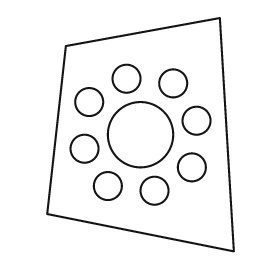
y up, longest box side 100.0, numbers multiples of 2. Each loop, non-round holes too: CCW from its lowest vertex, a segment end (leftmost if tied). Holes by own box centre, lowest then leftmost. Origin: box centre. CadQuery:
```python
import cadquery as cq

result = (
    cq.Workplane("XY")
    .moveTo(40.0, -50.0)
    .lineTo(34.0, 50.0)
    .lineTo(-32.0, 38.0)
    .lineTo(-40.0, -34.0)
    .close()
    .moveTo(6.0, -24.0)
    .circle(6.0)
    .moveTo(-14.0, -22.0)
    .circle(6.0)
    .moveTo(22.0, -14.0)
    .circle(6.0)
    .moveTo(-24.0, -6.0)
    .circle(6.0)
    .moveTo(0.0, 0.0)
    .circle(14.0)
    .moveTo(24.0, 6.0)
    .circle(6.0)
    .moveTo(-22.0, 14.0)
    .circle(6.0)
    .moveTo(14.0, 22.0)
    .circle(6.0)
    .moveTo(-6.0, 24.0)
    .circle(6.0)
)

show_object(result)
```